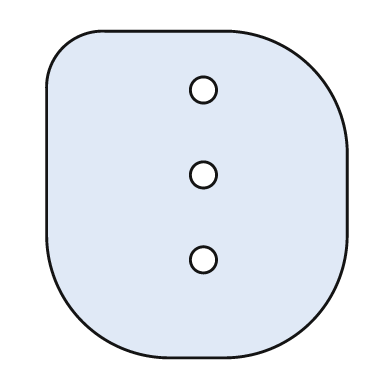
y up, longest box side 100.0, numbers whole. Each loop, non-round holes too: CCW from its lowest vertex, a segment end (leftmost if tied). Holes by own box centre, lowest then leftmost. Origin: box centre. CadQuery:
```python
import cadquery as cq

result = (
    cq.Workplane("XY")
    .moveTo(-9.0, -50.0)
    .lineTo(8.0, -50.0)
    .threePointArc((35.0, -39.0), (46.0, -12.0))
    .lineTo(46.0, 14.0)
    .threePointArc((35.0, 39.0), (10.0, 50.0))
    .lineTo(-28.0, 50.0)
    .threePointArc((-41.0, 45.0), (-46.0, 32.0))
    .lineTo(-46.0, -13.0)
    .threePointArc((-35.0, -39.0), (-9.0, -50.0))
    .close()
    .moveTo(2.0, -20.0)
    .circle(4.0)
    .moveTo(2.0, 6.0)
    .circle(4.0)
    .moveTo(2.0, 32.0)
    .circle(4.0)
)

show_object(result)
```